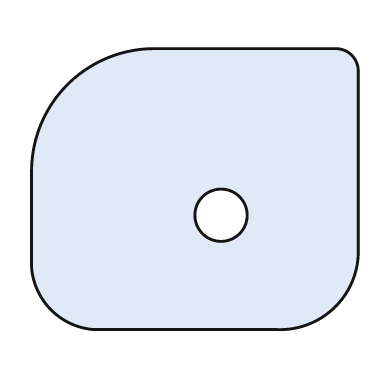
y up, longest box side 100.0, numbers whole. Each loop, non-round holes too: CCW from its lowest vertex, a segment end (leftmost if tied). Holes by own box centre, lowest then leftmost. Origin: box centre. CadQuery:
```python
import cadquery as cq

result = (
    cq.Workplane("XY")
    .moveTo(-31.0, -43.0)
    .lineTo(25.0, -43.0)
    .threePointArc((43.0, -36.0), (50.0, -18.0))
    .lineTo(50.0, 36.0)
    .threePointArc((48.0, 41.0), (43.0, 43.0))
    .lineTo(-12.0, 43.0)
    .threePointArc((-39.0, 32.0), (-50.0, 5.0))
    .lineTo(-50.0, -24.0)
    .threePointArc((-44.0, -37.0), (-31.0, -43.0))
    .close()
    .moveTo(8.0, -8.0)
    .circle(8.0)
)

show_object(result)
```